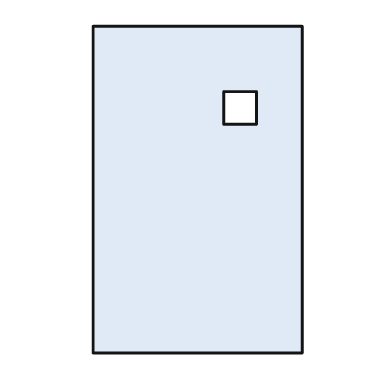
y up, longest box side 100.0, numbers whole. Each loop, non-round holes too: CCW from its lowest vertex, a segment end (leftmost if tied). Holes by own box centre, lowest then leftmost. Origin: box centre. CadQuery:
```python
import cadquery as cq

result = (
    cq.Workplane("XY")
    .moveTo(-32.0, -50.0)
    .lineTo(32.0, -50.0)
    .lineTo(32.0, 50.0)
    .lineTo(-32.0, 50.0)
    .close()
    .moveTo(8.0, 20.0)
    .lineTo(18.0, 20.0)
    .lineTo(18.0, 30.0)
    .lineTo(8.0, 30.0)
    .close()
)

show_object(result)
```